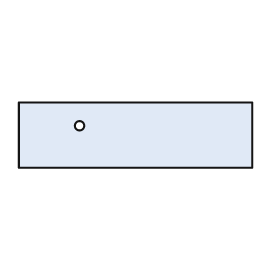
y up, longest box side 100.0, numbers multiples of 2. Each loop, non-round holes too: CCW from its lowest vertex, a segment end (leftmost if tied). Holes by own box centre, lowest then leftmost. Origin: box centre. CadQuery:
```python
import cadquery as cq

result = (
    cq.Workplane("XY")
    .moveTo(-50.0, -14.0)
    .lineTo(50.0, -14.0)
    .lineTo(50.0, 14.0)
    .lineTo(-50.0, 14.0)
    .close()
    .moveTo(-24.0, 4.0)
    .circle(2.0)
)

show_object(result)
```